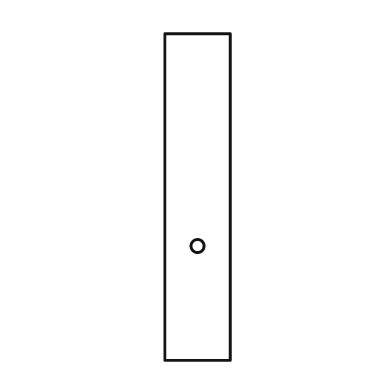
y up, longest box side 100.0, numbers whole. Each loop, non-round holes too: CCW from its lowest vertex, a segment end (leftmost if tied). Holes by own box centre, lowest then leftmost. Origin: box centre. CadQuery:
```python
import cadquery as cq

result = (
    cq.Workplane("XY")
    .moveTo(-10.0, -50.0)
    .lineTo(10.0, -50.0)
    .lineTo(10.0, 50.0)
    .lineTo(-10.0, 50.0)
    .close()
    .moveTo(0.0, -15.0)
    .circle(2.0)
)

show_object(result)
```